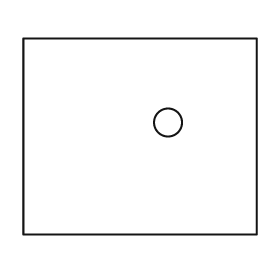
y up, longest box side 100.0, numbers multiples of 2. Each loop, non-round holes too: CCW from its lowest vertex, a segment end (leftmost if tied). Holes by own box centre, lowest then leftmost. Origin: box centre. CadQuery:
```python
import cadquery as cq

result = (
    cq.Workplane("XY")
    .moveTo(-50.0, -42.0)
    .lineTo(50.0, -42.0)
    .lineTo(50.0, 42.0)
    .lineTo(-50.0, 42.0)
    .close()
    .moveTo(12.0, 6.0)
    .circle(6.0)
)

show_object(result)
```